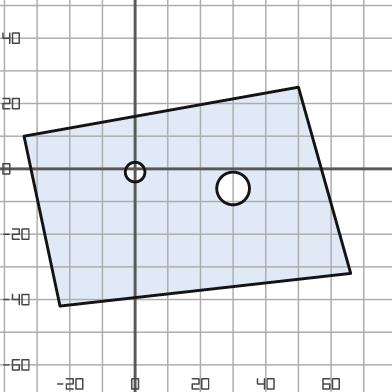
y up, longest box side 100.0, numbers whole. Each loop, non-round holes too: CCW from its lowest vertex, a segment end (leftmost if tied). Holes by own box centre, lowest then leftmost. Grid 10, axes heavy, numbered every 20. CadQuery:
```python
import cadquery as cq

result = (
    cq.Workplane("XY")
    .moveTo(-23.0, -42.0)
    .lineTo(66.0, -32.0)
    .lineTo(50.0, 25.0)
    .lineTo(-34.0, 10.0)
    .close()
    .moveTo(30.0, -6.0)
    .circle(5.0)
    .moveTo(0.0, -1.0)
    .circle(3.0)
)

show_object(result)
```